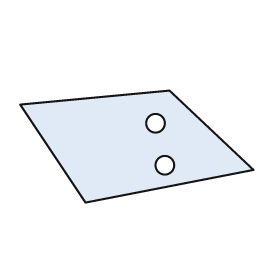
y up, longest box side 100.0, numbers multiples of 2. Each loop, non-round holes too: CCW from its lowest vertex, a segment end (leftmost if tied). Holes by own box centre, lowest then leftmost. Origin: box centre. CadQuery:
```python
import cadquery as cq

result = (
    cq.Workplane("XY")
    .moveTo(-22.0, -24.0)
    .lineTo(50.0, -10.0)
    .lineTo(14.0, 24.0)
    .lineTo(-50.0, 18.0)
    .close()
    .moveTo(12.0, -8.0)
    .circle(4.0)
    .moveTo(8.0, 10.0)
    .circle(4.0)
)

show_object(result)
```